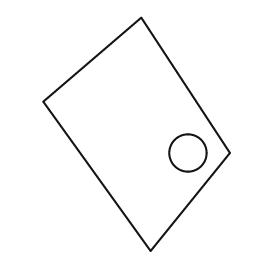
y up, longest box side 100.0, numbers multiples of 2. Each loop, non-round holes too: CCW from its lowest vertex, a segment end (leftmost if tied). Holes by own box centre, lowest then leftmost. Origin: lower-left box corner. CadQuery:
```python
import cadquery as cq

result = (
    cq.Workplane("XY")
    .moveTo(46.0, 0.0)
    .lineTo(80.0, 42.0)
    .lineTo(42.0, 100.0)
    .lineTo(0.0, 64.0)
    .close()
    .moveTo(62.0, 42.0)
    .circle(8.0)
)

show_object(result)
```